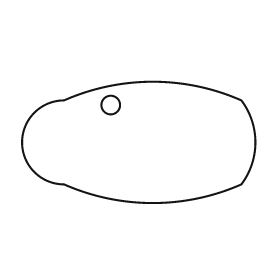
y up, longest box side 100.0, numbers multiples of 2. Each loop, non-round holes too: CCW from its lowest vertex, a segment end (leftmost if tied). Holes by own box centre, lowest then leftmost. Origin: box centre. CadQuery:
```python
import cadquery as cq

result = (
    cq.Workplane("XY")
    .moveTo(-32.0, -18.0)
    .threePointArc((6.0, -26.0), (44.0, -18.0))
    .threePointArc((50.0, 0.0), (44.0, 18.0))
    .threePointArc((6.0, 26.0), (-32.0, 18.0))
    .threePointArc((-50.0, 0.0), (-32.0, -18.0))
    .close()
    .moveTo(-12.0, 16.0)
    .circle(4.0)
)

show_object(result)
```